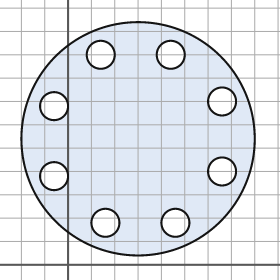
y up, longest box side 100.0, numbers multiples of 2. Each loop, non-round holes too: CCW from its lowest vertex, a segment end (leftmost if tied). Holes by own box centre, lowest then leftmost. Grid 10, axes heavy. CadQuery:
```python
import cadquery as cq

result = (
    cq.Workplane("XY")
    .moveTo(30.0, 54.0)
    .circle(50.0)
    .moveTo(16.0, 18.0)
    .circle(6.0)
    .moveTo(46.0, 18.0)
    .circle(6.0)
    .moveTo(-6.0, 38.0)
    .circle(6.0)
    .moveTo(66.0, 40.0)
    .circle(6.0)
    .moveTo(-6.0, 68.0)
    .circle(6.0)
    .moveTo(66.0, 70.0)
    .circle(6.0)
    .moveTo(14.0, 90.0)
    .circle(6.0)
    .moveTo(44.0, 90.0)
    .circle(6.0)
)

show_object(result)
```